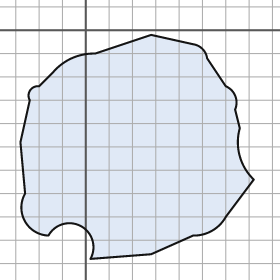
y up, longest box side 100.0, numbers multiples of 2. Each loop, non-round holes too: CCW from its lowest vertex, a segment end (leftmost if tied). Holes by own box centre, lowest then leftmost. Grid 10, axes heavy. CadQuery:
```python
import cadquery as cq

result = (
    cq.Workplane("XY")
    .moveTo(2.0, -98.0)
    .lineTo(28.0, -96.0)
    .lineTo(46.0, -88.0)
    .threePointArc((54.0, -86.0), (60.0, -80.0))
    .lineTo(72.0, -64.0)
    .threePointArc((66.0, -54.0), (66.0, -42.0))
    .lineTo(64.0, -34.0)
    .threePointArc((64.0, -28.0), (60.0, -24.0))
    .lineTo(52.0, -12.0)
    .threePointArc((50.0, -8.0), (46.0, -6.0))
    .lineTo(28.0, -2.0)
    .lineTo(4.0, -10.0)
    .threePointArc((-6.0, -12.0), (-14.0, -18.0))
    .lineTo(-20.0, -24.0)
    .threePointArc((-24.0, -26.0), (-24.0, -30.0))
    .lineTo(-28.0, -48.0)
    .lineTo(-26.0, -70.0)
    .threePointArc((-26.0, -82.0), (-16.0, -88.0))
    .threePointArc((-2.0, -84.0), (2.0, -98.0))
    .close()
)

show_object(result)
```